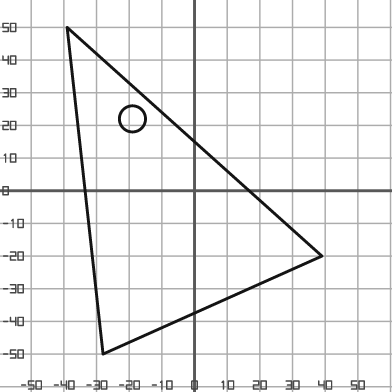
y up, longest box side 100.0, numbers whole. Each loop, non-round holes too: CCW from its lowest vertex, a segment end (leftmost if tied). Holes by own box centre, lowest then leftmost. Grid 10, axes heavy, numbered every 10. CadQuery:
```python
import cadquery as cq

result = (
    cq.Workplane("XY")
    .moveTo(-28.0, -50.0)
    .lineTo(39.0, -20.0)
    .lineTo(-39.0, 50.0)
    .close()
    .moveTo(-19.0, 22.0)
    .circle(4.0)
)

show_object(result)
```